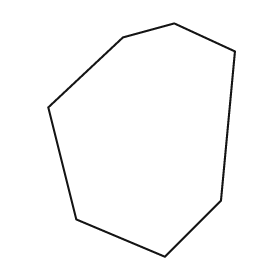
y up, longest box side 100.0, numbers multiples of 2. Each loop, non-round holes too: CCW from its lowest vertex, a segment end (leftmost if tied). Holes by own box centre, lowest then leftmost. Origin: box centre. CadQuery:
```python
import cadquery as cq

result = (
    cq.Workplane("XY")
    .moveTo(10.0, -50.0)
    .lineTo(34.0, -26.0)
    .lineTo(40.0, 38.0)
    .lineTo(14.0, 50.0)
    .lineTo(-8.0, 44.0)
    .lineTo(-40.0, 14.0)
    .lineTo(-28.0, -34.0)
    .close()
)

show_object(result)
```